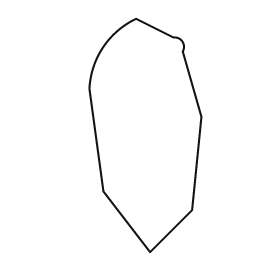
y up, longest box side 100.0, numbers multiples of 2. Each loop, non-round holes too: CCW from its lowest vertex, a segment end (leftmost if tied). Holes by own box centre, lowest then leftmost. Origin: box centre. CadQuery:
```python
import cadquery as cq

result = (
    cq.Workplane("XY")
    .moveTo(2.0, -50.0)
    .lineTo(20.0, -32.0)
    .lineTo(24.0, 8.0)
    .lineTo(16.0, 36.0)
    .threePointArc((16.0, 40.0), (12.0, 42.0))
    .lineTo(-4.0, 50.0)
    .threePointArc((-18.0, 38.0), (-24.0, 20.0))
    .lineTo(-18.0, -24.0)
    .close()
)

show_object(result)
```